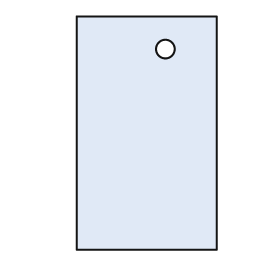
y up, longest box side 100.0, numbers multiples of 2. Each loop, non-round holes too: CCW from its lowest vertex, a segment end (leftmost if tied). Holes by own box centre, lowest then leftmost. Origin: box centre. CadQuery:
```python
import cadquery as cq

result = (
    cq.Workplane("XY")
    .moveTo(-30.0, -50.0)
    .lineTo(30.0, -50.0)
    .lineTo(30.0, 50.0)
    .lineTo(-30.0, 50.0)
    .close()
    .moveTo(8.0, 36.0)
    .circle(4.0)
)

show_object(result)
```